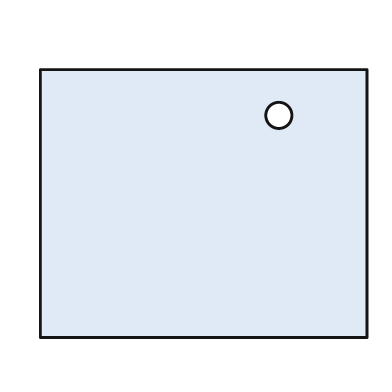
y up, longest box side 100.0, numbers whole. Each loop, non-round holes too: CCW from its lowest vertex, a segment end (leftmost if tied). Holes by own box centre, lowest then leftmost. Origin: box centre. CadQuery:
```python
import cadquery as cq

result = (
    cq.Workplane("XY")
    .moveTo(-50.0, -41.0)
    .lineTo(50.0, -41.0)
    .lineTo(50.0, 41.0)
    .lineTo(-50.0, 41.0)
    .close()
    .moveTo(23.0, 27.0)
    .circle(4.0)
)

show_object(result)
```